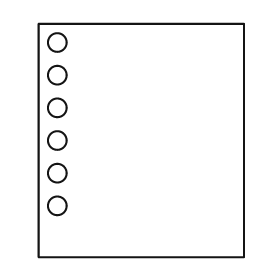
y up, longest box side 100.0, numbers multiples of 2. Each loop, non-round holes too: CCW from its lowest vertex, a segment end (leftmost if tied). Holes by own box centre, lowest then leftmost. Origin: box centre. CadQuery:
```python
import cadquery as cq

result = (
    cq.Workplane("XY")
    .moveTo(-44.0, -50.0)
    .lineTo(44.0, -50.0)
    .lineTo(44.0, 50.0)
    .lineTo(-44.0, 50.0)
    .close()
    .moveTo(-36.0, -28.0)
    .circle(4.0)
    .moveTo(-36.0, -14.0)
    .circle(4.0)
    .moveTo(-36.0, 0.0)
    .circle(4.0)
    .moveTo(-36.0, 14.0)
    .circle(4.0)
    .moveTo(-36.0, 28.0)
    .circle(4.0)
    .moveTo(-36.0, 42.0)
    .circle(4.0)
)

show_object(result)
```